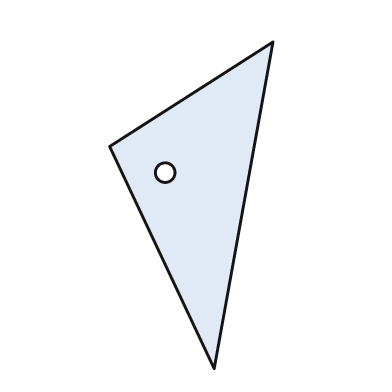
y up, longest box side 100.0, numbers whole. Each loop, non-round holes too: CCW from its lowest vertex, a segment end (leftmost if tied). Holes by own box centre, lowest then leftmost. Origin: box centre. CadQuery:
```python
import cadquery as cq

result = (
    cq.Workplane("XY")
    .moveTo(7.0, -50.0)
    .lineTo(25.0, 50.0)
    .lineTo(-25.0, 18.0)
    .close()
    .moveTo(-8.0, 10.0)
    .circle(3.0)
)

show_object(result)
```